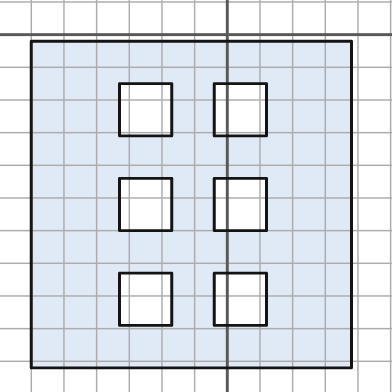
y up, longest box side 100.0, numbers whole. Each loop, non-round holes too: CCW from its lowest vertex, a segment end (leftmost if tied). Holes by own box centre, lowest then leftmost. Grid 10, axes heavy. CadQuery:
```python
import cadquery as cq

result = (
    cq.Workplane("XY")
    .moveTo(-60.0, -102.0)
    .lineTo(38.0, -102.0)
    .lineTo(38.0, -2.0)
    .lineTo(-60.0, -2.0)
    .close()
    .moveTo(-33.0, -89.0)
    .lineTo(-17.0, -89.0)
    .lineTo(-17.0, -73.0)
    .lineTo(-33.0, -73.0)
    .close()
    .moveTo(-4.0, -89.0)
    .lineTo(12.0, -89.0)
    .lineTo(12.0, -73.0)
    .lineTo(-4.0, -73.0)
    .close()
    .moveTo(-33.0, -60.0)
    .lineTo(-17.0, -60.0)
    .lineTo(-17.0, -44.0)
    .lineTo(-33.0, -44.0)
    .close()
    .moveTo(-4.0, -60.0)
    .lineTo(12.0, -60.0)
    .lineTo(12.0, -44.0)
    .lineTo(-4.0, -44.0)
    .close()
    .moveTo(-33.0, -31.0)
    .lineTo(-17.0, -31.0)
    .lineTo(-17.0, -15.0)
    .lineTo(-33.0, -15.0)
    .close()
    .moveTo(-4.0, -31.0)
    .lineTo(12.0, -31.0)
    .lineTo(12.0, -15.0)
    .lineTo(-4.0, -15.0)
    .close()
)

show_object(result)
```